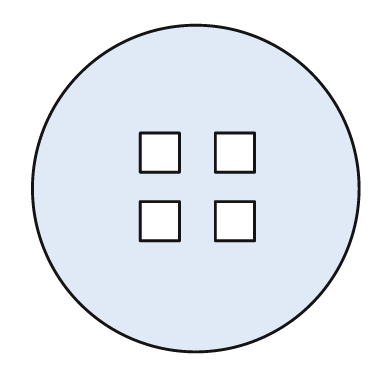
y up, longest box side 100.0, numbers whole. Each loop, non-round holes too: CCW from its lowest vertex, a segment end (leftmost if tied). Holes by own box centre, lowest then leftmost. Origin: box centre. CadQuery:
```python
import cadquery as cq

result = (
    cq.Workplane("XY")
    .moveTo(0.0, 0.0)
    .circle(50.0)
    .moveTo(-17.0, -16.0)
    .lineTo(-5.0, -16.0)
    .lineTo(-5.0, -4.0)
    .lineTo(-17.0, -4.0)
    .close()
    .moveTo(6.0, -16.0)
    .lineTo(18.0, -16.0)
    .lineTo(18.0, -4.0)
    .lineTo(6.0, -4.0)
    .close()
    .moveTo(-17.0, 5.0)
    .lineTo(-5.0, 5.0)
    .lineTo(-5.0, 17.0)
    .lineTo(-17.0, 17.0)
    .close()
    .moveTo(6.0, 5.0)
    .lineTo(18.0, 5.0)
    .lineTo(18.0, 17.0)
    .lineTo(6.0, 17.0)
    .close()
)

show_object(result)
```